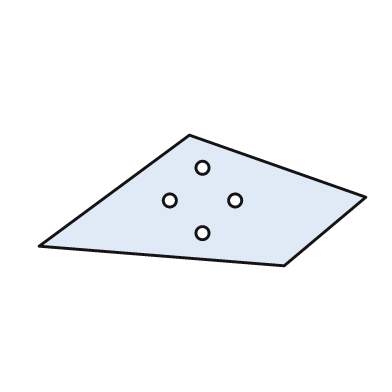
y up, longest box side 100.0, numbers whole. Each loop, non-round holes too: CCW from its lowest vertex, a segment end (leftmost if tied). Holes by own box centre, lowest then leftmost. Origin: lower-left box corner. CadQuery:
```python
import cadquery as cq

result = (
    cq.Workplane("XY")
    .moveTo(75.0, 0.0)
    .lineTo(100.0, 21.0)
    .lineTo(46.0, 40.0)
    .lineTo(0.0, 6.0)
    .close()
    .moveTo(50.0, 10.0)
    .circle(2.0)
    .moveTo(40.0, 20.0)
    .circle(2.0)
    .moveTo(60.0, 20.0)
    .circle(2.0)
    .moveTo(50.0, 30.0)
    .circle(2.0)
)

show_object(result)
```